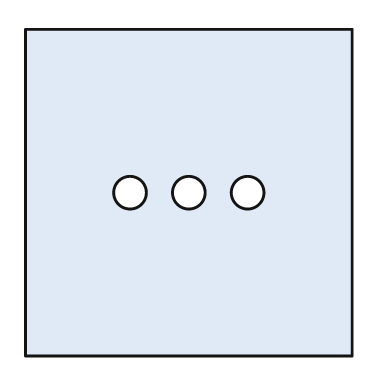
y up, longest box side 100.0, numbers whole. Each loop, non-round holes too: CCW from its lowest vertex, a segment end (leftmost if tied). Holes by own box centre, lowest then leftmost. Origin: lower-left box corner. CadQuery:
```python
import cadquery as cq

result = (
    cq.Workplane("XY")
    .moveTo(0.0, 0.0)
    .lineTo(100.0, 0.0)
    .lineTo(100.0, 100.0)
    .lineTo(0.0, 100.0)
    .close()
    .moveTo(32.0, 50.0)
    .circle(5.0)
    .moveTo(50.0, 50.0)
    .circle(5.0)
    .moveTo(68.0, 50.0)
    .circle(5.0)
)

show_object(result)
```